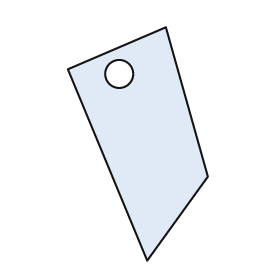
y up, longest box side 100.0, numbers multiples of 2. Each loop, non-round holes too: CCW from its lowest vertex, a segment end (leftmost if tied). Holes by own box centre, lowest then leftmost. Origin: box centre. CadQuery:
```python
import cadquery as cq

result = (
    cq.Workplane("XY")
    .moveTo(4.0, -50.0)
    .lineTo(30.0, -14.0)
    .lineTo(12.0, 50.0)
    .lineTo(-30.0, 32.0)
    .close()
    .moveTo(-8.0, 30.0)
    .circle(6.0)
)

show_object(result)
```